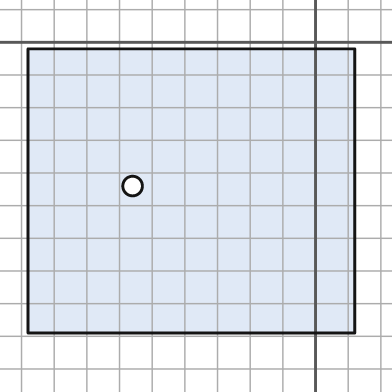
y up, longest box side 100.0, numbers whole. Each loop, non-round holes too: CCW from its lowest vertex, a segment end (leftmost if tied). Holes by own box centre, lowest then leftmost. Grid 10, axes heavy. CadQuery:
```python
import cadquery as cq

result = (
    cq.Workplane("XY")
    .moveTo(-88.0, -89.0)
    .lineTo(12.0, -89.0)
    .lineTo(12.0, -2.0)
    .lineTo(-88.0, -2.0)
    .close()
    .moveTo(-56.0, -44.0)
    .circle(3.0)
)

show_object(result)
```